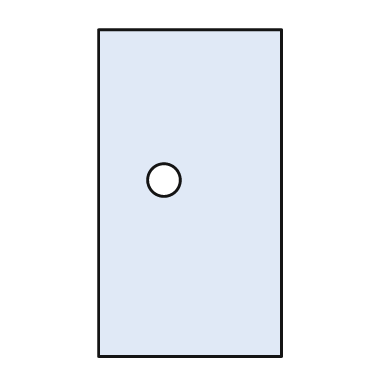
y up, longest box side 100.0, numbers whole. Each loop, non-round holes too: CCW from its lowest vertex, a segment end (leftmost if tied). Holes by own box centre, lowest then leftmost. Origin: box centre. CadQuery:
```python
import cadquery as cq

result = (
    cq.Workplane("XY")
    .moveTo(-28.0, -50.0)
    .lineTo(28.0, -50.0)
    .lineTo(28.0, 50.0)
    .lineTo(-28.0, 50.0)
    .close()
    .moveTo(-8.0, 4.0)
    .circle(5.0)
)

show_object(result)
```